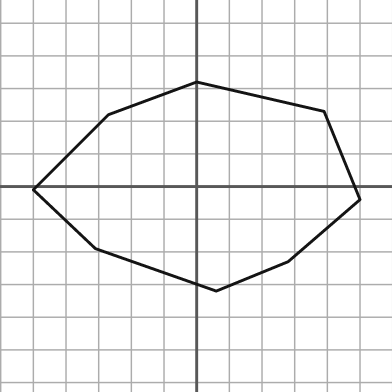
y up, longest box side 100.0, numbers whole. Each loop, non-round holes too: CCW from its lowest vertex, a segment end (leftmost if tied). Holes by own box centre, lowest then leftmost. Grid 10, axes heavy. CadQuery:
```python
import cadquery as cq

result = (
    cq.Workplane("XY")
    .moveTo(6.0, -32.0)
    .lineTo(28.0, -23.0)
    .lineTo(50.0, -4.0)
    .lineTo(39.0, 23.0)
    .lineTo(0.0, 32.0)
    .lineTo(-27.0, 22.0)
    .lineTo(-50.0, -1.0)
    .lineTo(-31.0, -19.0)
    .close()
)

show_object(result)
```